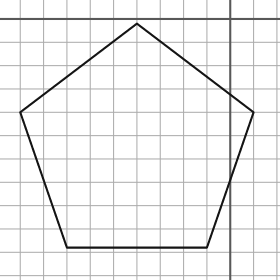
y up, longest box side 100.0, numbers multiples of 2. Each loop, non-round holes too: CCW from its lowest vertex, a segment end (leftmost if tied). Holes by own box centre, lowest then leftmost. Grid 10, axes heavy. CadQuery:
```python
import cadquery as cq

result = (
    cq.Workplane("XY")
    .moveTo(-70.0, -98.0)
    .lineTo(-10.0, -98.0)
    .lineTo(10.0, -40.0)
    .lineTo(-40.0, -2.0)
    .lineTo(-90.0, -40.0)
    .close()
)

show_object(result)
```